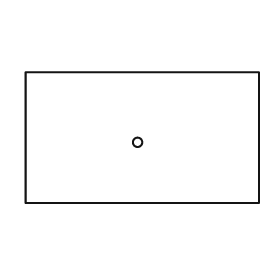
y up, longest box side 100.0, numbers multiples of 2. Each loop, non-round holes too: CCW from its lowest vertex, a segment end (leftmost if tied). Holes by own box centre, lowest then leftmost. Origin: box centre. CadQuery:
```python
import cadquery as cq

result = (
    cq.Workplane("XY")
    .moveTo(-50.0, -28.0)
    .lineTo(50.0, -28.0)
    .lineTo(50.0, 28.0)
    .lineTo(-50.0, 28.0)
    .close()
    .moveTo(-2.0, -2.0)
    .circle(2.0)
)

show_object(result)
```